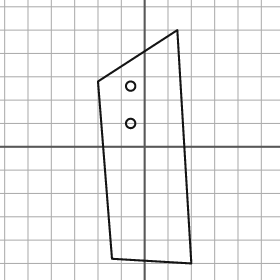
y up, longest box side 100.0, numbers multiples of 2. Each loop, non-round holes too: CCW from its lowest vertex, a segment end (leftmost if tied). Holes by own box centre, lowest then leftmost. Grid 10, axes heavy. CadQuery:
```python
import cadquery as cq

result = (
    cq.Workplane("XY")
    .moveTo(20.0, -50.0)
    .lineTo(14.0, 50.0)
    .lineTo(-20.0, 28.0)
    .lineTo(-14.0, -48.0)
    .close()
    .moveTo(-6.0, 10.0)
    .circle(2.0)
    .moveTo(-6.0, 26.0)
    .circle(2.0)
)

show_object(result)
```